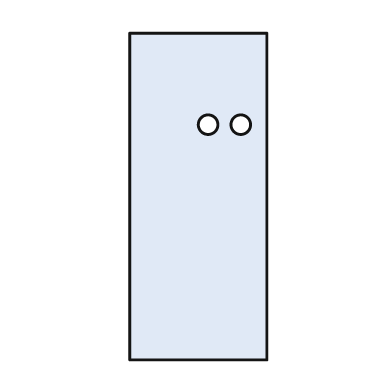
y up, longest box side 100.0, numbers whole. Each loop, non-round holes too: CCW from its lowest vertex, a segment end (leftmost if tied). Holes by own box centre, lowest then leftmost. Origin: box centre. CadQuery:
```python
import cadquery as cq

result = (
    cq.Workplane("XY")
    .moveTo(-21.0, -50.0)
    .lineTo(21.0, -50.0)
    .lineTo(21.0, 50.0)
    .lineTo(-21.0, 50.0)
    .close()
    .moveTo(3.0, 22.0)
    .circle(3.0)
    .moveTo(13.0, 22.0)
    .circle(3.0)
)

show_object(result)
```